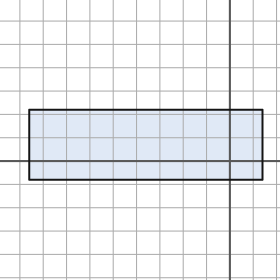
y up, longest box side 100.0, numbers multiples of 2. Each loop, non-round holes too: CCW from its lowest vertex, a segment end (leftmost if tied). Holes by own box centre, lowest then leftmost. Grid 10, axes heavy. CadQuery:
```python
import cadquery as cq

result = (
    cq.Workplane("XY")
    .moveTo(-86.0, -8.0)
    .lineTo(14.0, -8.0)
    .lineTo(14.0, 22.0)
    .lineTo(-86.0, 22.0)
    .close()
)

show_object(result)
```